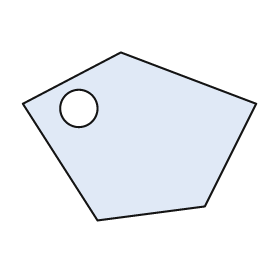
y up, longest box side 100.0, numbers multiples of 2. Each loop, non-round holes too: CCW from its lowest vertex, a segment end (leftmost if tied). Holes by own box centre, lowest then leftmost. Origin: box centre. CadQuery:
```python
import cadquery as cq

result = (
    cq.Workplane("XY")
    .moveTo(-18.0, -36.0)
    .lineTo(28.0, -30.0)
    .lineTo(50.0, 14.0)
    .lineTo(-8.0, 36.0)
    .lineTo(-50.0, 14.0)
    .close()
    .moveTo(-26.0, 12.0)
    .circle(8.0)
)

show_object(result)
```